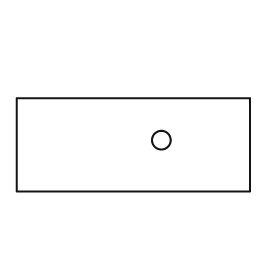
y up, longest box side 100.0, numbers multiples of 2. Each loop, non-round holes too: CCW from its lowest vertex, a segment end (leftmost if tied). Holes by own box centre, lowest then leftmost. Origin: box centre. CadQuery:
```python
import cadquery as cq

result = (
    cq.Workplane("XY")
    .moveTo(-50.0, -20.0)
    .lineTo(50.0, -20.0)
    .lineTo(50.0, 20.0)
    .lineTo(-50.0, 20.0)
    .close()
    .moveTo(12.0, 2.0)
    .circle(4.0)
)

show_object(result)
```